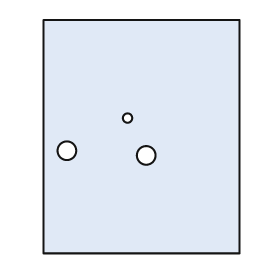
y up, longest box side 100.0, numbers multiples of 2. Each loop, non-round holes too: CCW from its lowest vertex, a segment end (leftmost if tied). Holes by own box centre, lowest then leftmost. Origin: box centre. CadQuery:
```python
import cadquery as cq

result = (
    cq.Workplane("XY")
    .moveTo(-42.0, -50.0)
    .lineTo(42.0, -50.0)
    .lineTo(42.0, 50.0)
    .lineTo(-42.0, 50.0)
    .close()
    .moveTo(2.0, -8.0)
    .circle(4.0)
    .moveTo(-32.0, -6.0)
    .circle(4.0)
    .moveTo(-6.0, 8.0)
    .circle(2.0)
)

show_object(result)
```